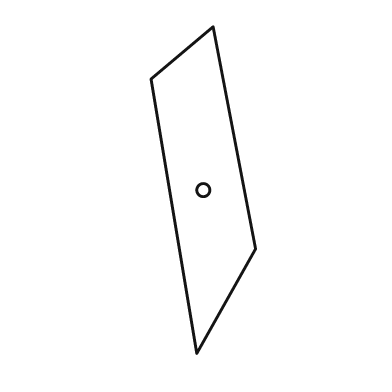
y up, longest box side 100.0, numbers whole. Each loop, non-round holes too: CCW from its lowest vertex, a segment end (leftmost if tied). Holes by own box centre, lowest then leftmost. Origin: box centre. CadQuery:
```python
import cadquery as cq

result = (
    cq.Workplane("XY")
    .moveTo(-2.0, -50.0)
    .lineTo(16.0, -18.0)
    .lineTo(3.0, 50.0)
    .lineTo(-16.0, 34.0)
    .close()
    .moveTo(0.0, 0.0)
    .circle(2.0)
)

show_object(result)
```